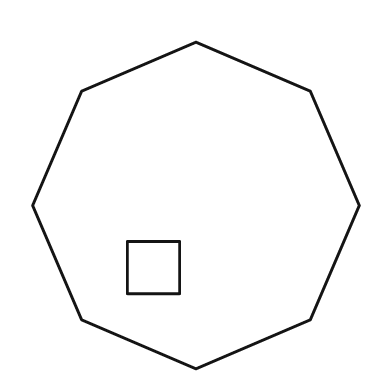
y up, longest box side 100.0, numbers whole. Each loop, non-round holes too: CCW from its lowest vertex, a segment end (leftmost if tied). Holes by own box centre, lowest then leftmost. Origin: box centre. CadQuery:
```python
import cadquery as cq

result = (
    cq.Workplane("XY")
    .moveTo(0.0, -50.0)
    .lineTo(35.0, -35.0)
    .lineTo(50.0, 0.0)
    .lineTo(35.0, 35.0)
    .lineTo(0.0, 50.0)
    .lineTo(-35.0, 35.0)
    .lineTo(-50.0, 0.0)
    .lineTo(-35.0, -35.0)
    .close()
    .moveTo(-21.0, -27.0)
    .lineTo(-5.0, -27.0)
    .lineTo(-5.0, -11.0)
    .lineTo(-21.0, -11.0)
    .close()
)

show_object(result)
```